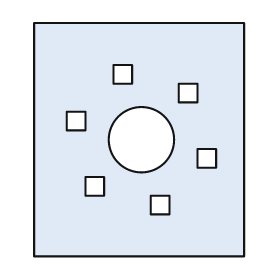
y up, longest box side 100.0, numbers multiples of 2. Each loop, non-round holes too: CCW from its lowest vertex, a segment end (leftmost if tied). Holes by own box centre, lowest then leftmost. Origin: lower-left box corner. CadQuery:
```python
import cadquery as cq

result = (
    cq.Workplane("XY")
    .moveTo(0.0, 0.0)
    .lineTo(90.0, 0.0)
    .lineTo(90.0, 100.0)
    .lineTo(0.0, 100.0)
    .close()
    .moveTo(50.0, 18.0)
    .lineTo(58.0, 18.0)
    .lineTo(58.0, 26.0)
    .lineTo(50.0, 26.0)
    .close()
    .moveTo(22.0, 26.0)
    .lineTo(30.0, 26.0)
    .lineTo(30.0, 34.0)
    .lineTo(22.0, 34.0)
    .close()
    .moveTo(70.0, 38.0)
    .lineTo(78.0, 38.0)
    .lineTo(78.0, 46.0)
    .lineTo(70.0, 46.0)
    .close()
    .moveTo(46.0, 50.0)
    .circle(14.0)
    .moveTo(14.0, 54.0)
    .lineTo(22.0, 54.0)
    .lineTo(22.0, 62.0)
    .lineTo(14.0, 62.0)
    .close()
    .moveTo(62.0, 66.0)
    .lineTo(70.0, 66.0)
    .lineTo(70.0, 74.0)
    .lineTo(62.0, 74.0)
    .close()
    .moveTo(34.0, 74.0)
    .lineTo(42.0, 74.0)
    .lineTo(42.0, 82.0)
    .lineTo(34.0, 82.0)
    .close()
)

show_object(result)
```